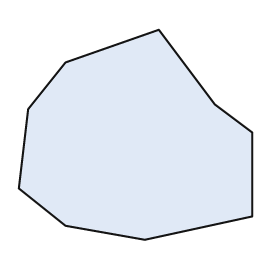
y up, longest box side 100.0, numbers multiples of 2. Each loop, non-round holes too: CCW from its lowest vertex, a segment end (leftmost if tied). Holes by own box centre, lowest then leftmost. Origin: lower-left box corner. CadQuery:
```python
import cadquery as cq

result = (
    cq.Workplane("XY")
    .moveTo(54.0, 0.0)
    .lineTo(100.0, 10.0)
    .lineTo(100.0, 46.0)
    .lineTo(84.0, 58.0)
    .lineTo(60.0, 90.0)
    .lineTo(20.0, 76.0)
    .lineTo(4.0, 56.0)
    .lineTo(0.0, 22.0)
    .lineTo(20.0, 6.0)
    .close()
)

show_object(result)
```